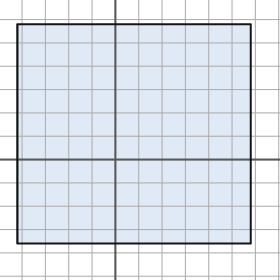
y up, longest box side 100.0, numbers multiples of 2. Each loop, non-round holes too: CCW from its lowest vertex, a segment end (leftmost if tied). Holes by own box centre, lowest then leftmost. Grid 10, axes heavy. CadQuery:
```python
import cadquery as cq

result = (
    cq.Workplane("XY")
    .moveTo(-42.0, -36.0)
    .lineTo(58.0, -36.0)
    .lineTo(58.0, 58.0)
    .lineTo(-42.0, 58.0)
    .close()
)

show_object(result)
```